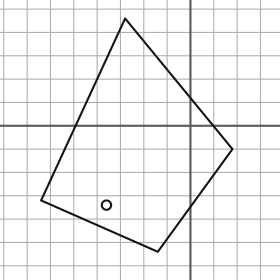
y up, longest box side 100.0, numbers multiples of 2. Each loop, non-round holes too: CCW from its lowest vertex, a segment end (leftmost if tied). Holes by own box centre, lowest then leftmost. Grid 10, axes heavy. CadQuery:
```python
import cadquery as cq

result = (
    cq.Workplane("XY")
    .moveTo(-14.0, -54.0)
    .lineTo(18.0, -10.0)
    .lineTo(-28.0, 46.0)
    .lineTo(-64.0, -32.0)
    .close()
    .moveTo(-36.0, -34.0)
    .circle(2.0)
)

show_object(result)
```